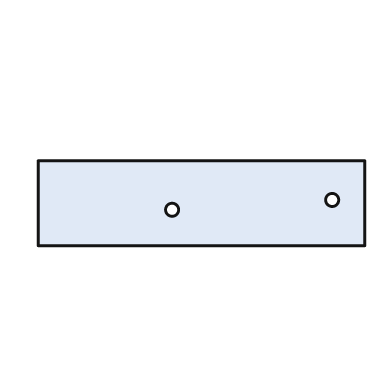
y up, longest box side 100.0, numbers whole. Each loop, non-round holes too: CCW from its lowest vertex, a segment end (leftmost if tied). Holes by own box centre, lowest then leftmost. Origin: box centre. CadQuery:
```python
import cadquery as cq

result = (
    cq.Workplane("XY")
    .moveTo(-50.0, -13.0)
    .lineTo(50.0, -13.0)
    .lineTo(50.0, 13.0)
    .lineTo(-50.0, 13.0)
    .close()
    .moveTo(-9.0, -2.0)
    .circle(2.0)
    .moveTo(40.0, 1.0)
    .circle(2.0)
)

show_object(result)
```